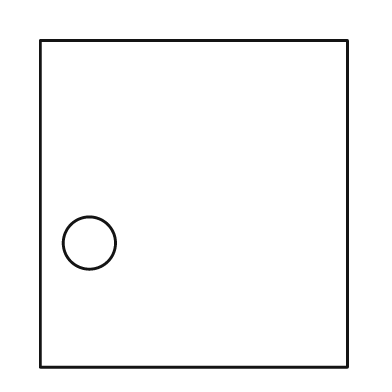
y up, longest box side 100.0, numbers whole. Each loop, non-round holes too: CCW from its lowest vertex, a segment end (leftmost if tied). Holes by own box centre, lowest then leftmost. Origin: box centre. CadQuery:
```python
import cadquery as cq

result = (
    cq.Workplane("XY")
    .moveTo(-47.0, -50.0)
    .lineTo(47.0, -50.0)
    .lineTo(47.0, 50.0)
    .lineTo(-47.0, 50.0)
    .close()
    .moveTo(-32.0, -12.0)
    .circle(8.0)
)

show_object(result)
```